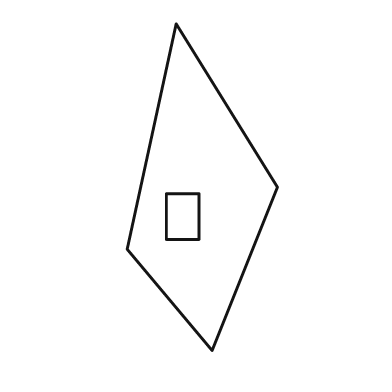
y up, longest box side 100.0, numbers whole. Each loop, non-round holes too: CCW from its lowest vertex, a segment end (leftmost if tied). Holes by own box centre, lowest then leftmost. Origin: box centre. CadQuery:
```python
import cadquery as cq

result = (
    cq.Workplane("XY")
    .moveTo(3.0, -50.0)
    .lineTo(23.0, 0.0)
    .lineTo(-8.0, 50.0)
    .lineTo(-23.0, -19.0)
    .close()
    .moveTo(-11.0, -16.0)
    .lineTo(-1.0, -16.0)
    .lineTo(-1.0, -2.0)
    .lineTo(-11.0, -2.0)
    .close()
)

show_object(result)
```